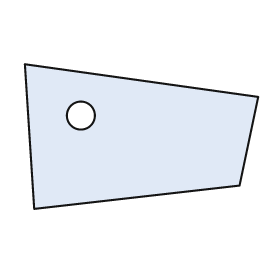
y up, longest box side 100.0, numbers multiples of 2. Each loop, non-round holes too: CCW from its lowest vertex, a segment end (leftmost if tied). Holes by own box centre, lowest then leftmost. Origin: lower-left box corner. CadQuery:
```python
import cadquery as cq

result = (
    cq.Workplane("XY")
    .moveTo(4.0, 0.0)
    .lineTo(92.0, 10.0)
    .lineTo(100.0, 48.0)
    .lineTo(0.0, 62.0)
    .close()
    .moveTo(24.0, 40.0)
    .circle(6.0)
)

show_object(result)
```